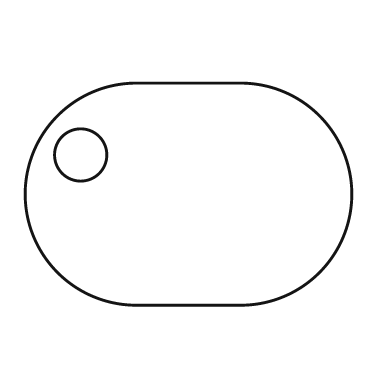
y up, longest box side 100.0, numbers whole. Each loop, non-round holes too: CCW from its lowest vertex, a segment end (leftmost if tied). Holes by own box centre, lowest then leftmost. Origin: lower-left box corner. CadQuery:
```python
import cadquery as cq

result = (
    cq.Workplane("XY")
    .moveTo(34.0, 0.0)
    .lineTo(66.0, 0.0)
    .threePointArc((100.0, 34.0), (66.0, 68.0))
    .lineTo(34.0, 68.0)
    .threePointArc((0.0, 34.0), (34.0, 0.0))
    .close()
    .moveTo(17.0, 46.0)
    .circle(8.0)
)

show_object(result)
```